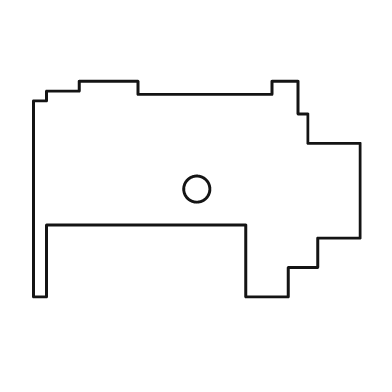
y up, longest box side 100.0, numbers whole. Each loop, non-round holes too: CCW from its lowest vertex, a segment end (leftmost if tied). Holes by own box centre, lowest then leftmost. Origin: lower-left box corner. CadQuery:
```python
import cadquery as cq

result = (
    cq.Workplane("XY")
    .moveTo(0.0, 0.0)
    .lineTo(4.0, 0.0)
    .lineTo(4.0, 22.0)
    .lineTo(65.0, 22.0)
    .lineTo(65.0, 0.0)
    .lineTo(78.0, 0.0)
    .lineTo(78.0, 9.0)
    .lineTo(87.0, 9.0)
    .lineTo(87.0, 18.0)
    .lineTo(100.0, 18.0)
    .lineTo(100.0, 47.0)
    .lineTo(84.0, 47.0)
    .lineTo(84.0, 56.0)
    .lineTo(81.0, 56.0)
    .lineTo(81.0, 66.0)
    .lineTo(73.0, 66.0)
    .lineTo(73.0, 62.0)
    .lineTo(32.0, 62.0)
    .lineTo(32.0, 66.0)
    .lineTo(14.0, 66.0)
    .lineTo(14.0, 63.0)
    .lineTo(4.0, 63.0)
    .lineTo(4.0, 60.0)
    .lineTo(0.0, 60.0)
    .close()
    .moveTo(50.0, 33.0)
    .circle(4.0)
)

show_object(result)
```